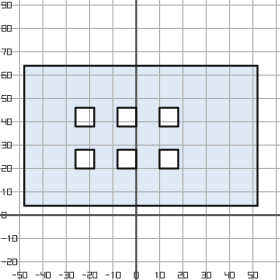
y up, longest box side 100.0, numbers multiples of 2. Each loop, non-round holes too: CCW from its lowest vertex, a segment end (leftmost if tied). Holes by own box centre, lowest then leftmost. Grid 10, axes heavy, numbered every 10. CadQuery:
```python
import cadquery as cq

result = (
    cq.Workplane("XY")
    .moveTo(-48.0, 4.0)
    .lineTo(52.0, 4.0)
    .lineTo(52.0, 64.0)
    .lineTo(-48.0, 64.0)
    .close()
    .moveTo(-26.0, 20.0)
    .lineTo(-18.0, 20.0)
    .lineTo(-18.0, 28.0)
    .lineTo(-26.0, 28.0)
    .close()
    .moveTo(-8.0, 20.0)
    .lineTo(0.0, 20.0)
    .lineTo(0.0, 28.0)
    .lineTo(-8.0, 28.0)
    .close()
    .moveTo(10.0, 20.0)
    .lineTo(18.0, 20.0)
    .lineTo(18.0, 28.0)
    .lineTo(10.0, 28.0)
    .close()
    .moveTo(-26.0, 38.0)
    .lineTo(-18.0, 38.0)
    .lineTo(-18.0, 46.0)
    .lineTo(-26.0, 46.0)
    .close()
    .moveTo(-8.0, 38.0)
    .lineTo(0.0, 38.0)
    .lineTo(0.0, 46.0)
    .lineTo(-8.0, 46.0)
    .close()
    .moveTo(10.0, 38.0)
    .lineTo(18.0, 38.0)
    .lineTo(18.0, 46.0)
    .lineTo(10.0, 46.0)
    .close()
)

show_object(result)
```